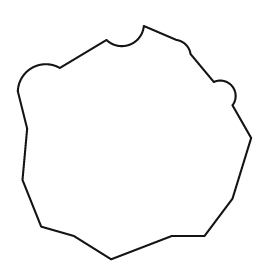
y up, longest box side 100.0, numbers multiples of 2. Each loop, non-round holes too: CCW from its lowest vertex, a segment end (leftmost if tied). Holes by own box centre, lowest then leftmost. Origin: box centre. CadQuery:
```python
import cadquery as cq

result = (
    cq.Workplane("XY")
    .moveTo(-10.0, -50.0)
    .lineTo(16.0, -40.0)
    .lineTo(30.0, -40.0)
    .lineTo(42.0, -24.0)
    .lineTo(50.0, 2.0)
    .lineTo(42.0, 16.0)
    .threePointArc((42.0, 24.0), (34.0, 26.0))
    .lineTo(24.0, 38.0)
    .threePointArc((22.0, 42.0), (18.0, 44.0))
    .lineTo(4.0, 50.0)
    .threePointArc((-2.0, 42.0), (-12.0, 44.0))
    .lineTo(-32.0, 32.0)
    .threePointArc((-44.0, 32.0), (-50.0, 22.0))
    .lineTo(-46.0, 6.0)
    .lineTo(-48.0, -16.0)
    .lineTo(-40.0, -36.0)
    .lineTo(-26.0, -40.0)
    .close()
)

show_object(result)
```